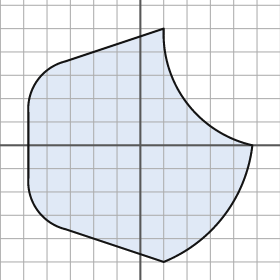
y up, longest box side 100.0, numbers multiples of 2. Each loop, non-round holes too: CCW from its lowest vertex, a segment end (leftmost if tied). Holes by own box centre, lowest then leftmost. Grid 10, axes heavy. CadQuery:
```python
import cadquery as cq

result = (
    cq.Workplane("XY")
    .moveTo(10.0, -50.0)
    .threePointArc((36.0, -30.0), (48.0, 0.0))
    .threePointArc((20.0, 18.0), (10.0, 50.0))
    .lineTo(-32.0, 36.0)
    .threePointArc((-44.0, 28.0), (-48.0, 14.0))
    .lineTo(-48.0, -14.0)
    .threePointArc((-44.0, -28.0), (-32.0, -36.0))
    .close()
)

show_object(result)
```